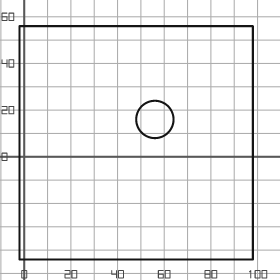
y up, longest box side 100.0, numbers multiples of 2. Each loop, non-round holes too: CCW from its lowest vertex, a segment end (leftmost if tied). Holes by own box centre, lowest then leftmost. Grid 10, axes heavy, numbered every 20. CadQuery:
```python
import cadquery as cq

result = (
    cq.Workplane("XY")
    .moveTo(-2.0, -44.0)
    .lineTo(98.0, -44.0)
    .lineTo(98.0, 56.0)
    .lineTo(-2.0, 56.0)
    .close()
    .moveTo(56.0, 16.0)
    .circle(8.0)
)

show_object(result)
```